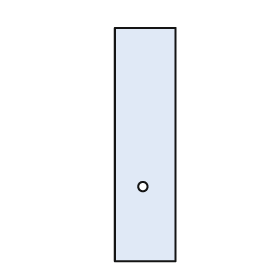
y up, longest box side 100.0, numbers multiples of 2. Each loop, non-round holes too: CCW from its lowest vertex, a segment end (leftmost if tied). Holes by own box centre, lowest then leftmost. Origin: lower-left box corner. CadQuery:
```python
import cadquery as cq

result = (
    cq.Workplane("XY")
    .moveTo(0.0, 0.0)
    .lineTo(26.0, 0.0)
    .lineTo(26.0, 100.0)
    .lineTo(0.0, 100.0)
    .close()
    .moveTo(12.0, 32.0)
    .circle(2.0)
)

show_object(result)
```